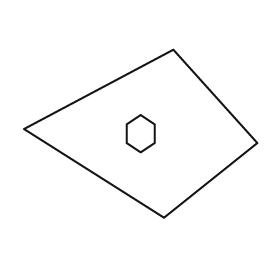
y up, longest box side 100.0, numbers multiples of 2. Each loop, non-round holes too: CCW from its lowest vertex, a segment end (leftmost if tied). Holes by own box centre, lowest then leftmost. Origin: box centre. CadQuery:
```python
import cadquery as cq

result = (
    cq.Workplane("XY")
    .moveTo(10.0, -36.0)
    .lineTo(50.0, -4.0)
    .lineTo(14.0, 36.0)
    .lineTo(-50.0, 2.0)
    .close()
    .moveTo(0.0, -8.0)
    .lineTo(6.0, -4.0)
    .lineTo(6.0, 4.0)
    .lineTo(0.0, 8.0)
    .lineTo(-6.0, 4.0)
    .lineTo(-6.0, -4.0)
    .close()
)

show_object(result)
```